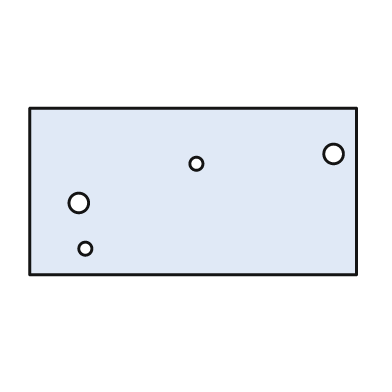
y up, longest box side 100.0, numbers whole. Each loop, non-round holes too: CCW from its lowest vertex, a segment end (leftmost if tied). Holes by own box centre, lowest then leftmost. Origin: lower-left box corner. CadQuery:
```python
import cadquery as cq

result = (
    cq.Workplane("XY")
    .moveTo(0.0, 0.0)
    .lineTo(100.0, 0.0)
    .lineTo(100.0, 51.0)
    .lineTo(0.0, 51.0)
    .close()
    .moveTo(17.0, 8.0)
    .circle(2.0)
    .moveTo(15.0, 22.0)
    .circle(3.0)
    .moveTo(51.0, 34.0)
    .circle(2.0)
    .moveTo(93.0, 37.0)
    .circle(3.0)
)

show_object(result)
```